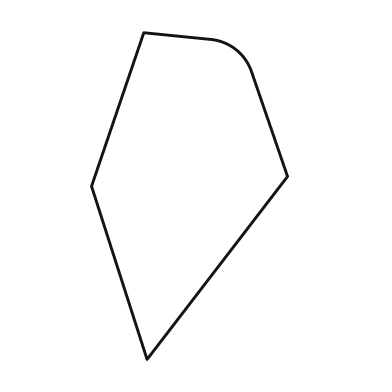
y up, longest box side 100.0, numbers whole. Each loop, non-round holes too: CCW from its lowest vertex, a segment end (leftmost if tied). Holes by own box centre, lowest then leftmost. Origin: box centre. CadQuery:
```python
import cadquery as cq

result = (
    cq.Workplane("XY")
    .moveTo(-13.0, -50.0)
    .lineTo(30.0, 6.0)
    .lineTo(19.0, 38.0)
    .threePointArc((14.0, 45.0), (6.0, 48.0))
    .lineTo(-14.0, 50.0)
    .lineTo(-30.0, 3.0)
    .close()
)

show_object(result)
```